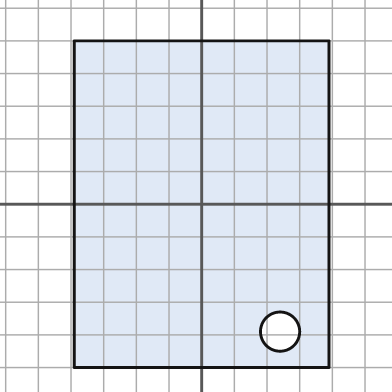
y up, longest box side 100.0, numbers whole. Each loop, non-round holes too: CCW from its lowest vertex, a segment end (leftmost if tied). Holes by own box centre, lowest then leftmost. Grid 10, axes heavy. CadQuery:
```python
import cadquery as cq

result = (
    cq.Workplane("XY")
    .moveTo(-39.0, -50.0)
    .lineTo(39.0, -50.0)
    .lineTo(39.0, 50.0)
    .lineTo(-39.0, 50.0)
    .close()
    .moveTo(24.0, -39.0)
    .circle(6.0)
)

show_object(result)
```